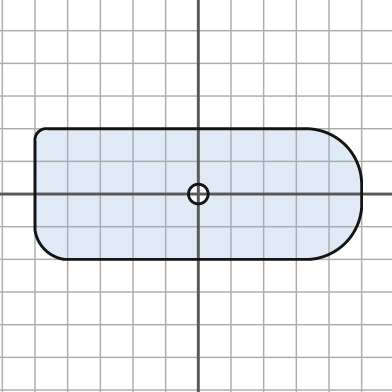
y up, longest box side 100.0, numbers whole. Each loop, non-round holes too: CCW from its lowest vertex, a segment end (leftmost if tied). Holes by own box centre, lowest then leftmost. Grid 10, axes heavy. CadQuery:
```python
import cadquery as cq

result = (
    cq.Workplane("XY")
    .moveTo(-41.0, -20.0)
    .lineTo(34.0, -20.0)
    .threePointArc((45.0, -15.0), (50.0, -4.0))
    .lineTo(50.0, 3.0)
    .threePointArc((45.0, 15.0), (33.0, 20.0))
    .lineTo(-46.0, 20.0)
    .threePointArc((-49.0, 19.0), (-50.0, 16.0))
    .lineTo(-50.0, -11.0)
    .threePointArc((-47.0, -17.0), (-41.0, -20.0))
    .close()
    .moveTo(0.0, 0.0)
    .circle(3.0)
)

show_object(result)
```